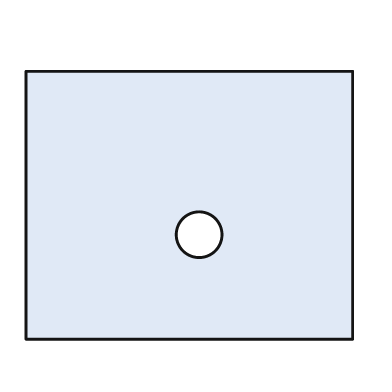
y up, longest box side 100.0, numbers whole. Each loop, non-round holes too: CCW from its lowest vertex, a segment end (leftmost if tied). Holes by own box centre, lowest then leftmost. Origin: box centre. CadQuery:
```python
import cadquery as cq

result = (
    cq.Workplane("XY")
    .moveTo(-50.0, -41.0)
    .lineTo(50.0, -41.0)
    .lineTo(50.0, 41.0)
    .lineTo(-50.0, 41.0)
    .close()
    .moveTo(3.0, -9.0)
    .circle(7.0)
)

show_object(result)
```